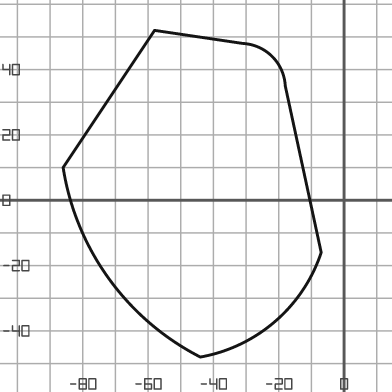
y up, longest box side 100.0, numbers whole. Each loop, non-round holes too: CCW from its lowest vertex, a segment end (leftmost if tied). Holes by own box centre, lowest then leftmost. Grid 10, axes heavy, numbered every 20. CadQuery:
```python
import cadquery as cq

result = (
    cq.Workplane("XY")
    .moveTo(-44.0, -48.0)
    .threePointArc((-21.0, -37.0), (-7.0, -16.0))
    .lineTo(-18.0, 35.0)
    .threePointArc((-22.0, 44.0), (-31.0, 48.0))
    .lineTo(-58.0, 52.0)
    .lineTo(-86.0, 10.0)
    .threePointArc((-72.0, -24.0), (-44.0, -48.0))
    .close()
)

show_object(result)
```